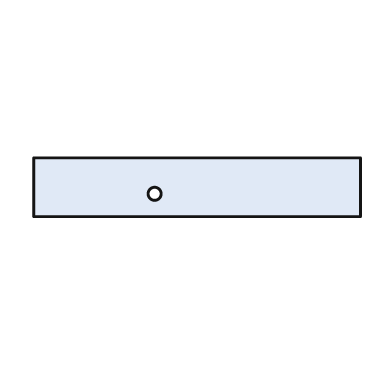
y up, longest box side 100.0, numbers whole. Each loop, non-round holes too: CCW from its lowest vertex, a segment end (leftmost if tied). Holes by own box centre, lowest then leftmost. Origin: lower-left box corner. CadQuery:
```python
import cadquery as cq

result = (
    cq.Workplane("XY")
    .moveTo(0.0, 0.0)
    .lineTo(100.0, 0.0)
    .lineTo(100.0, 18.0)
    .lineTo(0.0, 18.0)
    .close()
    .moveTo(37.0, 7.0)
    .circle(2.0)
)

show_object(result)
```